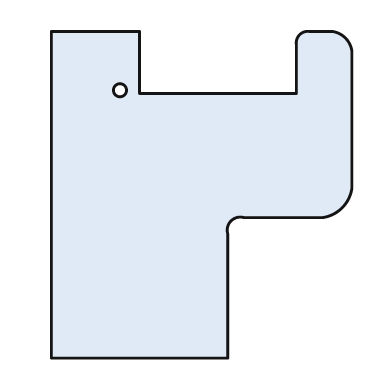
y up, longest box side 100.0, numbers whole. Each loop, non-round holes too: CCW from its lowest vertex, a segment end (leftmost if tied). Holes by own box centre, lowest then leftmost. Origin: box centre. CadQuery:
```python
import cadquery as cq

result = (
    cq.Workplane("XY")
    .moveTo(-46.0, -50.0)
    .lineTo(8.0, -50.0)
    .lineTo(8.0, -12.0)
    .threePointArc((9.0, -8.0), (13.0, -7.0))
    .lineTo(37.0, -7.0)
    .threePointArc((43.0, -4.0), (46.0, 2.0))
    .lineTo(46.0, 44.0)
    .threePointArc((44.0, 48.0), (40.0, 50.0))
    .lineTo(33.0, 50.0)
    .threePointArc((30.0, 49.0), (29.0, 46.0))
    .lineTo(29.0, 31.0)
    .lineTo(-19.0, 31.0)
    .lineTo(-19.0, 50.0)
    .lineTo(-46.0, 50.0)
    .close()
    .moveTo(-25.0, 32.0)
    .circle(2.0)
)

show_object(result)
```